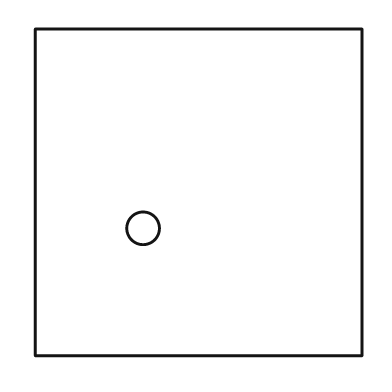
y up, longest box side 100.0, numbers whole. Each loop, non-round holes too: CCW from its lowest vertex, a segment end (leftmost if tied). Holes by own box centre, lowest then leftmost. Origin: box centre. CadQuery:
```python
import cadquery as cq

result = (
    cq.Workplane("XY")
    .moveTo(-50.0, -50.0)
    .lineTo(50.0, -50.0)
    .lineTo(50.0, 50.0)
    .lineTo(-50.0, 50.0)
    .close()
    .moveTo(-17.0, -11.0)
    .circle(5.0)
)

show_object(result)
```